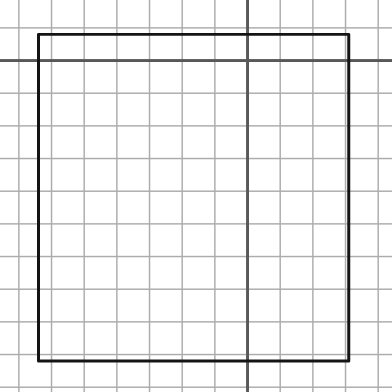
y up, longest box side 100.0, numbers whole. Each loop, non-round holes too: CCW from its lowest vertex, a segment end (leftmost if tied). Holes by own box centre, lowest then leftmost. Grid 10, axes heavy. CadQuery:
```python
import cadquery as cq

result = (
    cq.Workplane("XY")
    .moveTo(-64.0, -92.0)
    .lineTo(31.0, -92.0)
    .lineTo(31.0, 8.0)
    .lineTo(-64.0, 8.0)
    .close()
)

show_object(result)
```